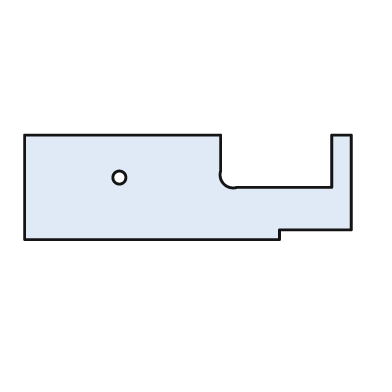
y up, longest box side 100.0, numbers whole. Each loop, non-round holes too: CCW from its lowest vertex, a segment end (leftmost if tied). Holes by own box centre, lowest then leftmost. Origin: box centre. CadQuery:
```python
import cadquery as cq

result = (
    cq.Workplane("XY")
    .moveTo(-50.0, -16.0)
    .lineTo(28.0, -16.0)
    .lineTo(28.0, -13.0)
    .lineTo(50.0, -13.0)
    .lineTo(50.0, 16.0)
    .lineTo(44.0, 16.0)
    .lineTo(44.0, 0.0)
    .lineTo(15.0, 0.0)
    .threePointArc((11.0, 1.0), (10.0, 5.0))
    .lineTo(10.0, 16.0)
    .lineTo(-50.0, 16.0)
    .close()
    .moveTo(-21.0, 3.0)
    .circle(2.0)
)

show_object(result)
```